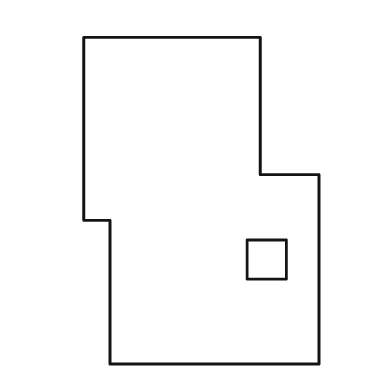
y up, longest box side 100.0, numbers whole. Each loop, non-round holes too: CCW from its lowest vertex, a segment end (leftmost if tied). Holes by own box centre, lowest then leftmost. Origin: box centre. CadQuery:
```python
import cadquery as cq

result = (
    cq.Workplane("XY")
    .moveTo(-28.0, -50.0)
    .lineTo(36.0, -50.0)
    .lineTo(36.0, 8.0)
    .lineTo(18.0, 8.0)
    .lineTo(18.0, 50.0)
    .lineTo(-36.0, 50.0)
    .lineTo(-36.0, -6.0)
    .lineTo(-28.0, -6.0)
    .close()
    .moveTo(14.0, -24.0)
    .lineTo(26.0, -24.0)
    .lineTo(26.0, -12.0)
    .lineTo(14.0, -12.0)
    .close()
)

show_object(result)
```